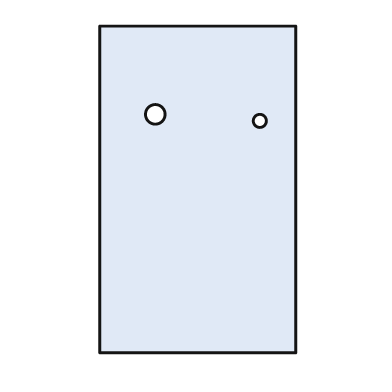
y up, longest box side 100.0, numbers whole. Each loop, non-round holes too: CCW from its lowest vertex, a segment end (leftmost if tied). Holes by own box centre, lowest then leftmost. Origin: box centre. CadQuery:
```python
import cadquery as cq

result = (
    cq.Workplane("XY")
    .moveTo(-30.0, -50.0)
    .lineTo(30.0, -50.0)
    .lineTo(30.0, 50.0)
    .lineTo(-30.0, 50.0)
    .close()
    .moveTo(19.0, 21.0)
    .circle(2.0)
    .moveTo(-13.0, 23.0)
    .circle(3.0)
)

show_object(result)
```